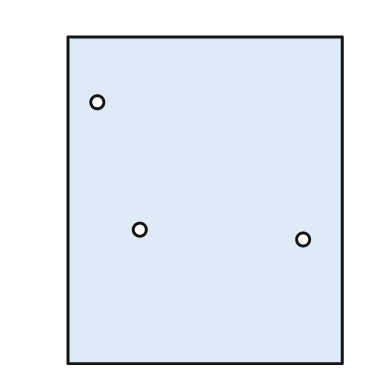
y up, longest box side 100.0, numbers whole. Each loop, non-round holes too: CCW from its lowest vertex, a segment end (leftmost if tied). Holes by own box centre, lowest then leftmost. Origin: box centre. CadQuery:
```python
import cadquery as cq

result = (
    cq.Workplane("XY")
    .moveTo(-42.0, -50.0)
    .lineTo(42.0, -50.0)
    .lineTo(42.0, 50.0)
    .lineTo(-42.0, 50.0)
    .close()
    .moveTo(30.0, -12.0)
    .circle(2.0)
    .moveTo(-20.0, -9.0)
    .circle(2.0)
    .moveTo(-33.0, 30.0)
    .circle(2.0)
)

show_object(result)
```